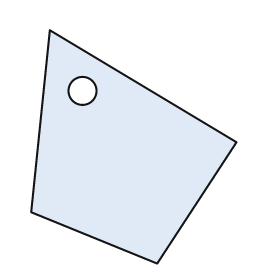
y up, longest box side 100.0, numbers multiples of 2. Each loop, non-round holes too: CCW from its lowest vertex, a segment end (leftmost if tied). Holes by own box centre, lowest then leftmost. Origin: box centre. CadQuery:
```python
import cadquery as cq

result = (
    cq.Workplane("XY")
    .moveTo(10.0, -50.0)
    .lineTo(44.0, 2.0)
    .lineTo(-36.0, 50.0)
    .lineTo(-44.0, -28.0)
    .close()
    .moveTo(-22.0, 24.0)
    .circle(6.0)
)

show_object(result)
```